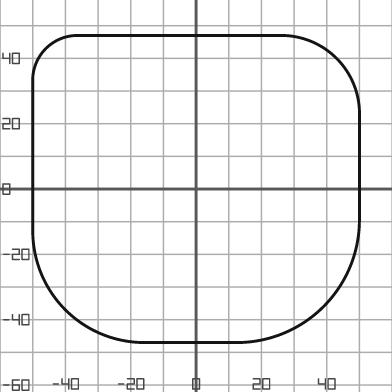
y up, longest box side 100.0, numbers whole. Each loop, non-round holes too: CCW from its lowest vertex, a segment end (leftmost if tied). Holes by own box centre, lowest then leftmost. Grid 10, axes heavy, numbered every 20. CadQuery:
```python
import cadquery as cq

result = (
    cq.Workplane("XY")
    .moveTo(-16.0, -47.0)
    .lineTo(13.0, -47.0)
    .threePointArc((39.0, -36.0), (50.0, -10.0))
    .lineTo(50.0, 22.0)
    .threePointArc((43.0, 40.0), (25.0, 47.0))
    .lineTo(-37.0, 47.0)
    .threePointArc((-46.0, 43.0), (-50.0, 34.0))
    .lineTo(-50.0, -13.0)
    .threePointArc((-40.0, -37.0), (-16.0, -47.0))
    .close()
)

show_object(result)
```